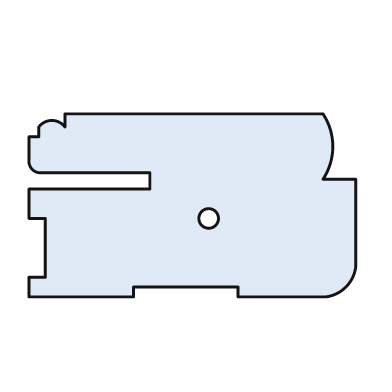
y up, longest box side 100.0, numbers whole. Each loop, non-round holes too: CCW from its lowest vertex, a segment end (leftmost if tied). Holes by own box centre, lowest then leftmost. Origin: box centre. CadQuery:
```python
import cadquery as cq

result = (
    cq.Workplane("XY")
    .moveTo(-50.0, -28.0)
    .lineTo(-18.0, -28.0)
    .lineTo(-18.0, -25.0)
    .lineTo(14.0, -25.0)
    .lineTo(14.0, -28.0)
    .lineTo(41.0, -28.0)
    .threePointArc((47.0, -25.0), (50.0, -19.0))
    .lineTo(50.0, 8.0)
    .lineTo(40.0, 8.0)
    .threePointArc((43.0, 18.0), (40.0, 28.0))
    .lineTo(-39.0, 28.0)
    .lineTo(-39.0, 24.0)
    .threePointArc((-43.0, 26.0), (-47.0, 24.0))
    .lineTo(-47.0, 21.0)
    .lineTo(-50.0, 21.0)
    .lineTo(-50.0, 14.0)
    .threePointArc((-49.0, 11.0), (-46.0, 10.0))
    .lineTo(-13.0, 10.0)
    .lineTo(-13.0, 5.0)
    .lineTo(-50.0, 5.0)
    .lineTo(-50.0, -4.0)
    .lineTo(-45.0, -4.0)
    .lineTo(-45.0, -22.0)
    .lineTo(-50.0, -22.0)
    .close()
    .moveTo(5.0, -4.0)
    .circle(3.0)
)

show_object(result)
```